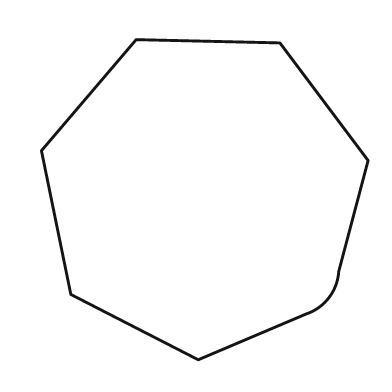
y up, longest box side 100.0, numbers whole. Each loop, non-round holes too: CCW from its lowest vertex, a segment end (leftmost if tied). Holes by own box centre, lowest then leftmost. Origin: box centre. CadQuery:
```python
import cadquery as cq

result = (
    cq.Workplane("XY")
    .moveTo(-2.0, -49.0)
    .lineTo(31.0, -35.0)
    .threePointArc((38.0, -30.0), (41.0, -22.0))
    .lineTo(50.0, 12.0)
    .lineTo(23.0, 48.0)
    .lineTo(-21.0, 49.0)
    .lineTo(-50.0, 15.0)
    .lineTo(-41.0, -29.0)
    .close()
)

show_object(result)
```